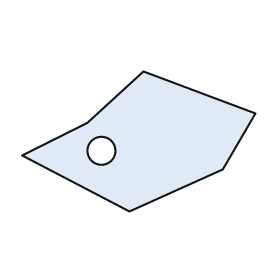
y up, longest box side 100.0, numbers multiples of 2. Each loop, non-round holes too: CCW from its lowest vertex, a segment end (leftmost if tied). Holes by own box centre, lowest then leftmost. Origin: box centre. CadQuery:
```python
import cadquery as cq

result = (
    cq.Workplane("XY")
    .moveTo(-4.0, -30.0)
    .lineTo(36.0, -12.0)
    .lineTo(50.0, 12.0)
    .lineTo(2.0, 30.0)
    .lineTo(-22.0, 8.0)
    .lineTo(-50.0, -6.0)
    .close()
    .moveTo(-16.0, -4.0)
    .circle(6.0)
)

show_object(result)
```